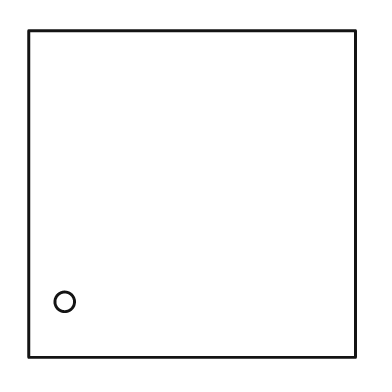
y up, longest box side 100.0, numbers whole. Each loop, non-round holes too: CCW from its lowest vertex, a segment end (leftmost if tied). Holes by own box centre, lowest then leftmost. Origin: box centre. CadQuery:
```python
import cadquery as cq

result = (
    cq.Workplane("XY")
    .moveTo(-50.0, -50.0)
    .lineTo(50.0, -50.0)
    .lineTo(50.0, 50.0)
    .lineTo(-50.0, 50.0)
    .close()
    .moveTo(-39.0, -33.0)
    .circle(3.0)
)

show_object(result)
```